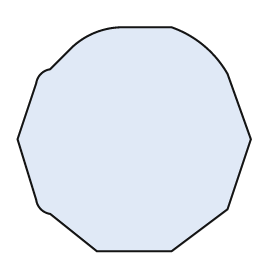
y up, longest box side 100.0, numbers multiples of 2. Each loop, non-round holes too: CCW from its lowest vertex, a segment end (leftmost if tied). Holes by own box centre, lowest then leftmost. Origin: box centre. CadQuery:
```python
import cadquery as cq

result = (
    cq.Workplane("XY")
    .moveTo(-16.0, -48.0)
    .lineTo(16.0, -48.0)
    .lineTo(40.0, -30.0)
    .lineTo(50.0, 0.0)
    .lineTo(40.0, 28.0)
    .threePointArc((30.0, 40.0), (16.0, 48.0))
    .lineTo(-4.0, 48.0)
    .threePointArc((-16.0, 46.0), (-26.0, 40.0))
    .lineTo(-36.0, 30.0)
    .threePointArc((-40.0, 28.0), (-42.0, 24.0))
    .lineTo(-50.0, 0.0)
    .lineTo(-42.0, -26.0)
    .threePointArc((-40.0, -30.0), (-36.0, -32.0))
    .close()
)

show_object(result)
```